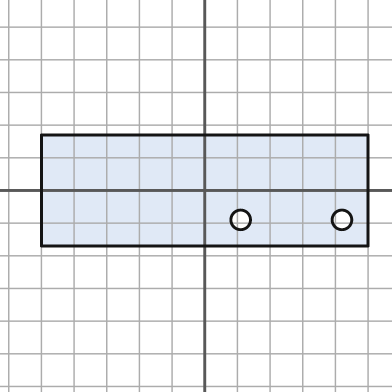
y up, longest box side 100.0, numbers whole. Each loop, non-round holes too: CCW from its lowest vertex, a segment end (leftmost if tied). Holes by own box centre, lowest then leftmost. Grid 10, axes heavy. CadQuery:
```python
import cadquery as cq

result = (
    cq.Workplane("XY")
    .moveTo(-50.0, -17.0)
    .lineTo(50.0, -17.0)
    .lineTo(50.0, 17.0)
    .lineTo(-50.0, 17.0)
    .close()
    .moveTo(11.0, -9.0)
    .circle(3.0)
    .moveTo(42.0, -9.0)
    .circle(3.0)
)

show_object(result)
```